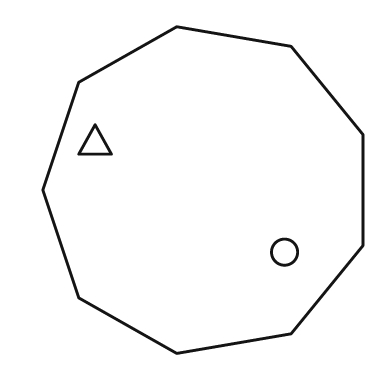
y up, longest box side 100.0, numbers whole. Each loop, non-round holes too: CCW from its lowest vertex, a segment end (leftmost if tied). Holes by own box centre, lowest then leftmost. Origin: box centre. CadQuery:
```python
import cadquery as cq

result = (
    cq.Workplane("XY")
    .moveTo(-8.0, -50.0)
    .lineTo(27.0, -44.0)
    .lineTo(49.0, -17.0)
    .lineTo(49.0, 17.0)
    .lineTo(27.0, 44.0)
    .lineTo(-8.0, 50.0)
    .lineTo(-38.0, 33.0)
    .lineTo(-49.0, 0.0)
    .lineTo(-38.0, -33.0)
    .close()
    .moveTo(25.0, -19.0)
    .circle(4.0)
    .moveTo(-38.0, 11.0)
    .lineTo(-28.0, 11.0)
    .lineTo(-33.0, 20.0)
    .close()
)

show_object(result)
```